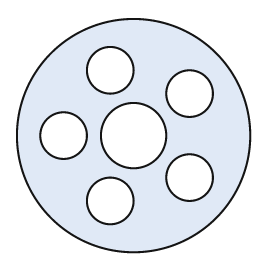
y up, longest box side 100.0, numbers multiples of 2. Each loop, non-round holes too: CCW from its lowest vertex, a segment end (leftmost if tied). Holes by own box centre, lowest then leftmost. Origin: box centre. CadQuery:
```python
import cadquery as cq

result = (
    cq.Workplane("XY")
    .moveTo(0.0, 0.0)
    .circle(50.0)
    .moveTo(-10.0, -28.0)
    .circle(10.0)
    .moveTo(24.0, -18.0)
    .circle(10.0)
    .moveTo(-30.0, 0.0)
    .circle(10.0)
    .moveTo(0.0, 0.0)
    .circle(14.0)
    .moveTo(24.0, 18.0)
    .circle(10.0)
    .moveTo(-10.0, 28.0)
    .circle(10.0)
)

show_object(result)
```